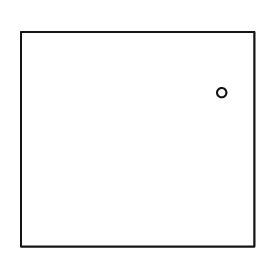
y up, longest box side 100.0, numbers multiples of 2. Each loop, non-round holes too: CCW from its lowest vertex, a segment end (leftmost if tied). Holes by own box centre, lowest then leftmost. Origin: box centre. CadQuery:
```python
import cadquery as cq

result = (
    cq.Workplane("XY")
    .moveTo(-50.0, -46.0)
    .lineTo(50.0, -46.0)
    .lineTo(50.0, 46.0)
    .lineTo(-50.0, 46.0)
    .close()
    .moveTo(36.0, 20.0)
    .circle(2.0)
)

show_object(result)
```